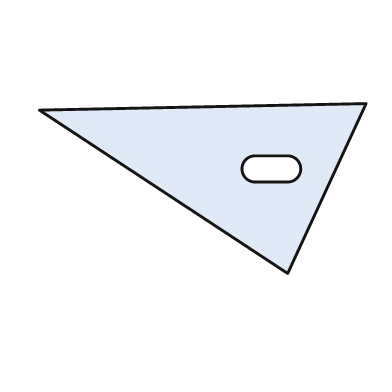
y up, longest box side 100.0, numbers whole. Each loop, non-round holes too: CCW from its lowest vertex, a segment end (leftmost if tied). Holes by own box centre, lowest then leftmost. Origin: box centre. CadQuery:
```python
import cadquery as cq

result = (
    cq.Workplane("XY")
    .moveTo(26.0, -26.0)
    .lineTo(50.0, 26.0)
    .lineTo(-50.0, 24.0)
    .close()
    .moveTo(16.0, 2.0)
    .lineTo(26.0, 2.0)
    .threePointArc((30.0, 6.0), (26.0, 10.0))
    .lineTo(16.0, 10.0)
    .threePointArc((12.0, 6.0), (16.0, 2.0))
    .close()
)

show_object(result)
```